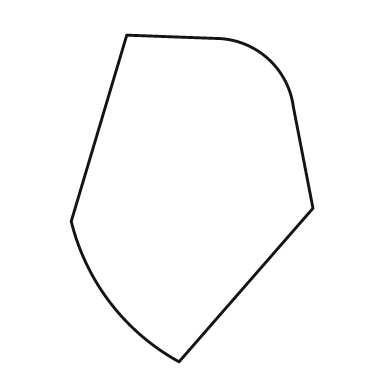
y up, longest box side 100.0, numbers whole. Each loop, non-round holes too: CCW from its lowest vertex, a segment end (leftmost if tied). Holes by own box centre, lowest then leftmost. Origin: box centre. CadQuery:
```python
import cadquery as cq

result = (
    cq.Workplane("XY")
    .moveTo(-4.0, -50.0)
    .lineTo(37.0, -3.0)
    .lineTo(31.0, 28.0)
    .threePointArc((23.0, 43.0), (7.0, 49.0))
    .lineTo(-20.0, 50.0)
    .lineTo(-37.0, -7.0)
    .threePointArc((-25.0, -32.0), (-4.0, -50.0))
    .close()
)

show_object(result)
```